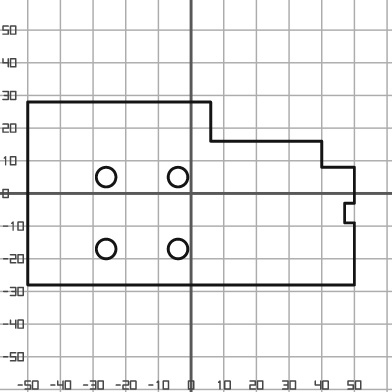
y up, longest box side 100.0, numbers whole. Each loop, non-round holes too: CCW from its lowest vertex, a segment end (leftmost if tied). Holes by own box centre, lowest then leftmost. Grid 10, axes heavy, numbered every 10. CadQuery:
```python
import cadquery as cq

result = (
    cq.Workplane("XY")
    .moveTo(-50.0, -28.0)
    .lineTo(50.0, -28.0)
    .lineTo(50.0, -9.0)
    .lineTo(47.0, -9.0)
    .lineTo(47.0, -3.0)
    .lineTo(50.0, -3.0)
    .lineTo(50.0, 8.0)
    .lineTo(40.0, 8.0)
    .lineTo(40.0, 16.0)
    .lineTo(6.0, 16.0)
    .lineTo(6.0, 28.0)
    .lineTo(-50.0, 28.0)
    .close()
    .moveTo(-26.0, -17.0)
    .circle(3.0)
    .moveTo(-4.0, -17.0)
    .circle(3.0)
    .moveTo(-26.0, 5.0)
    .circle(3.0)
    .moveTo(-4.0, 5.0)
    .circle(3.0)
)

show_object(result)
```